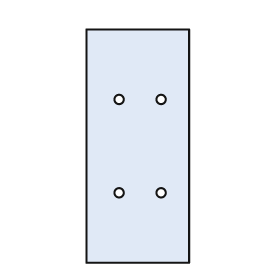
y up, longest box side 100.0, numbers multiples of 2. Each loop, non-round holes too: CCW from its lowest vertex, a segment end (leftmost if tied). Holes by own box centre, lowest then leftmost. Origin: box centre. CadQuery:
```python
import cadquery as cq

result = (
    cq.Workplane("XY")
    .moveTo(-22.0, -50.0)
    .lineTo(22.0, -50.0)
    .lineTo(22.0, 50.0)
    .lineTo(-22.0, 50.0)
    .close()
    .moveTo(-8.0, -20.0)
    .circle(2.0)
    .moveTo(10.0, -20.0)
    .circle(2.0)
    .moveTo(-8.0, 20.0)
    .circle(2.0)
    .moveTo(10.0, 20.0)
    .circle(2.0)
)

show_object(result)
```